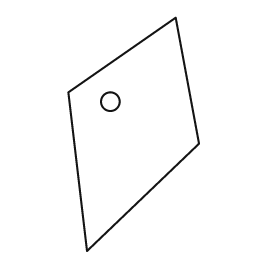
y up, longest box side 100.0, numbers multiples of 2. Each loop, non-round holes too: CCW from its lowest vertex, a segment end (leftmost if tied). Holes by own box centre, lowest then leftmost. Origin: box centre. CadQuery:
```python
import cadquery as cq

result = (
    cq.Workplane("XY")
    .moveTo(-20.0, -50.0)
    .lineTo(28.0, -4.0)
    .lineTo(18.0, 50.0)
    .lineTo(-28.0, 18.0)
    .close()
    .moveTo(-10.0, 14.0)
    .circle(4.0)
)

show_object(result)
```